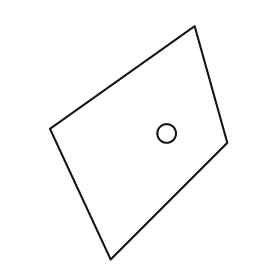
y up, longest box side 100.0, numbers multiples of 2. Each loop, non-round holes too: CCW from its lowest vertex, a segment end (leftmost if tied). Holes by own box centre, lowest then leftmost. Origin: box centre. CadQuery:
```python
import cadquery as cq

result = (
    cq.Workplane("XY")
    .moveTo(-12.0, -50.0)
    .lineTo(38.0, 0.0)
    .lineTo(24.0, 50.0)
    .lineTo(-38.0, 6.0)
    .close()
    .moveTo(12.0, 4.0)
    .circle(4.0)
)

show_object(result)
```